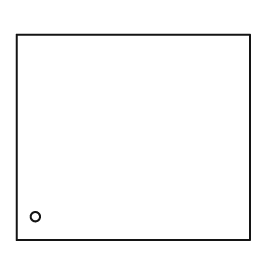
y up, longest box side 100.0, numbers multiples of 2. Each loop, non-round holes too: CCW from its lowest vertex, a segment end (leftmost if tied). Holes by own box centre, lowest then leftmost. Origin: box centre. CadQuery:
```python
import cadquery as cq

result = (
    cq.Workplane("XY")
    .moveTo(-50.0, -44.0)
    .lineTo(50.0, -44.0)
    .lineTo(50.0, 44.0)
    .lineTo(-50.0, 44.0)
    .close()
    .moveTo(-42.0, -34.0)
    .circle(2.0)
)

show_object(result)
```